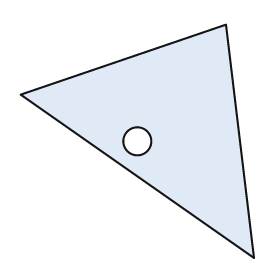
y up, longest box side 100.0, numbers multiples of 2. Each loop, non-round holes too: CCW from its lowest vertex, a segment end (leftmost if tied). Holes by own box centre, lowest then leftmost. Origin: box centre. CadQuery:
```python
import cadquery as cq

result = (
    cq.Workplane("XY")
    .moveTo(50.0, -50.0)
    .lineTo(38.0, 50.0)
    .lineTo(-50.0, 20.0)
    .close()
    .moveTo(0.0, 0.0)
    .circle(6.0)
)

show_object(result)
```